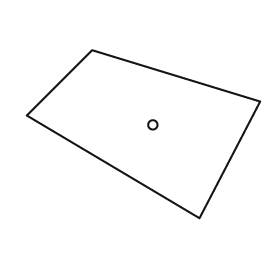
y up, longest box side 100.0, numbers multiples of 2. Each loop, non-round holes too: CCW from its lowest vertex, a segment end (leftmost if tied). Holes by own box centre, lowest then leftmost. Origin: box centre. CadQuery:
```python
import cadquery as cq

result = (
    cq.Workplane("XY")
    .moveTo(24.0, -36.0)
    .lineTo(50.0, 14.0)
    .lineTo(-22.0, 36.0)
    .lineTo(-50.0, 8.0)
    .close()
    .moveTo(4.0, 4.0)
    .circle(2.0)
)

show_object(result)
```